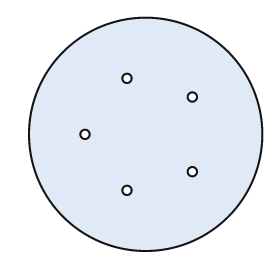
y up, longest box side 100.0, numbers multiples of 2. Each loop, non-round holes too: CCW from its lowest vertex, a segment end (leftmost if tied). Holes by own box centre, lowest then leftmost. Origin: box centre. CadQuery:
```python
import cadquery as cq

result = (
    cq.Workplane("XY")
    .moveTo(0.0, 0.0)
    .circle(50.0)
    .moveTo(-8.0, -24.0)
    .circle(2.0)
    .moveTo(20.0, -16.0)
    .circle(2.0)
    .moveTo(-26.0, 0.0)
    .circle(2.0)
    .moveTo(20.0, 16.0)
    .circle(2.0)
    .moveTo(-8.0, 24.0)
    .circle(2.0)
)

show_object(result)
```